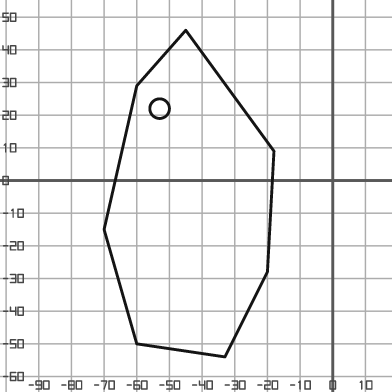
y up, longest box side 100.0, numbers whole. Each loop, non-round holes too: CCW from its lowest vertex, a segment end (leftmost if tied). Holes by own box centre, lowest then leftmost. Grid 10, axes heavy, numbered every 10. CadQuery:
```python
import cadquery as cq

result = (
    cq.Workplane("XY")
    .moveTo(-33.0, -54.0)
    .lineTo(-20.0, -28.0)
    .lineTo(-18.0, 9.0)
    .lineTo(-45.0, 46.0)
    .lineTo(-60.0, 29.0)
    .lineTo(-70.0, -15.0)
    .lineTo(-60.0, -50.0)
    .close()
    .moveTo(-53.0, 22.0)
    .circle(3.0)
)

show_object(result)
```